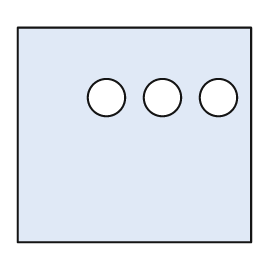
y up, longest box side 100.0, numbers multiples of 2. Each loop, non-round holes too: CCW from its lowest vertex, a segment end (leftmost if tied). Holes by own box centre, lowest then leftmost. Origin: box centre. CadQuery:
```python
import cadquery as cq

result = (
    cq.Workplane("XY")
    .moveTo(-50.0, -46.0)
    .lineTo(50.0, -46.0)
    .lineTo(50.0, 46.0)
    .lineTo(-50.0, 46.0)
    .close()
    .moveTo(-12.0, 16.0)
    .circle(8.0)
    .moveTo(12.0, 16.0)
    .circle(8.0)
    .moveTo(36.0, 16.0)
    .circle(8.0)
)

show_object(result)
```